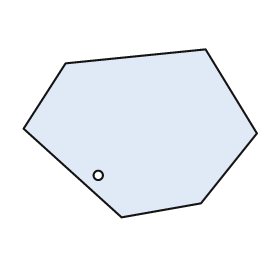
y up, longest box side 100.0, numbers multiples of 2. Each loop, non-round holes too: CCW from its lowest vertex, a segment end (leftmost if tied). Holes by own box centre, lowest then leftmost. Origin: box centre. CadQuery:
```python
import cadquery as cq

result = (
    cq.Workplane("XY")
    .moveTo(-8.0, -36.0)
    .lineTo(26.0, -30.0)
    .lineTo(50.0, 0.0)
    .lineTo(28.0, 36.0)
    .lineTo(-32.0, 30.0)
    .lineTo(-50.0, 2.0)
    .close()
    .moveTo(-18.0, -18.0)
    .circle(2.0)
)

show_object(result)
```